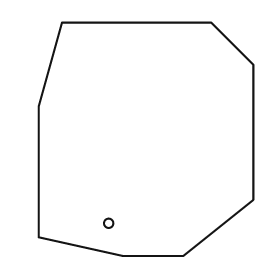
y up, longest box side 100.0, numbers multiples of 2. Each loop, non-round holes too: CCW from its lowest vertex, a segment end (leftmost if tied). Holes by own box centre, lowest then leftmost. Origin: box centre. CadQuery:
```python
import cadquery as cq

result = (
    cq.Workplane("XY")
    .moveTo(-10.0, -50.0)
    .lineTo(16.0, -50.0)
    .lineTo(46.0, -26.0)
    .lineTo(46.0, 32.0)
    .lineTo(28.0, 50.0)
    .lineTo(-36.0, 50.0)
    .lineTo(-46.0, 14.0)
    .lineTo(-46.0, -42.0)
    .close()
    .moveTo(-16.0, -36.0)
    .circle(2.0)
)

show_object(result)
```